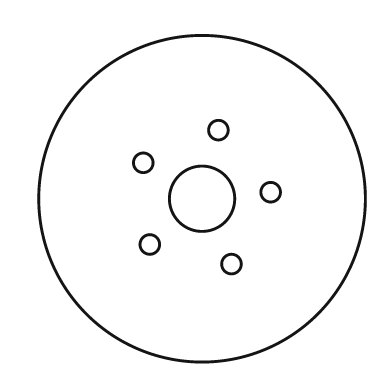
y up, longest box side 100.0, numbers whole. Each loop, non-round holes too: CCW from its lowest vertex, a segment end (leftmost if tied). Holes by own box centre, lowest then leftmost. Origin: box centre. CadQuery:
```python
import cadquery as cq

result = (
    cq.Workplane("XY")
    .moveTo(0.0, 0.0)
    .circle(50.0)
    .moveTo(9.0, -20.0)
    .circle(3.0)
    .moveTo(-16.0, -14.0)
    .circle(3.0)
    .moveTo(0.0, 0.0)
    .circle(10.0)
    .moveTo(21.0, 2.0)
    .circle(3.0)
    .moveTo(-18.0, 11.0)
    .circle(3.0)
    .moveTo(5.0, 21.0)
    .circle(3.0)
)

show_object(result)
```